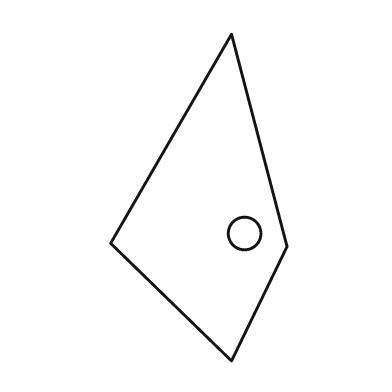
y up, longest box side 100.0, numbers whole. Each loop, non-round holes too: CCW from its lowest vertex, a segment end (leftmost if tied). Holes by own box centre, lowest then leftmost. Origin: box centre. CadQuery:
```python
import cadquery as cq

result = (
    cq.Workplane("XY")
    .moveTo(10.0, -50.0)
    .lineTo(27.0, -15.0)
    .lineTo(10.0, 50.0)
    .lineTo(-27.0, -14.0)
    .close()
    .moveTo(14.0, -11.0)
    .circle(5.0)
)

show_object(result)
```